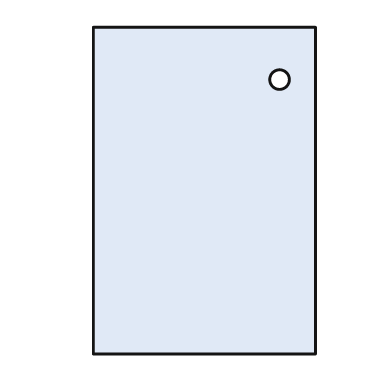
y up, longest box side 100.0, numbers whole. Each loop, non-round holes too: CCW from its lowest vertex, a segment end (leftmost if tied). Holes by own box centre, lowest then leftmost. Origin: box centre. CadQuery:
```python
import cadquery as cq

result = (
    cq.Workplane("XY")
    .moveTo(-34.0, -50.0)
    .lineTo(34.0, -50.0)
    .lineTo(34.0, 50.0)
    .lineTo(-34.0, 50.0)
    .close()
    .moveTo(23.0, 34.0)
    .circle(3.0)
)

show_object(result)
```